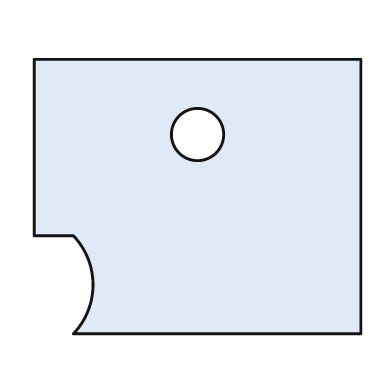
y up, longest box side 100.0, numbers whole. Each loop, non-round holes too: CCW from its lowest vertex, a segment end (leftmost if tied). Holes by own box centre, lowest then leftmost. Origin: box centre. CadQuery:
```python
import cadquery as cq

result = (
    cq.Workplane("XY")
    .moveTo(-38.0, -42.0)
    .lineTo(50.0, -42.0)
    .lineTo(50.0, 42.0)
    .lineTo(-50.0, 42.0)
    .lineTo(-50.0, -12.0)
    .lineTo(-38.0, -12.0)
    .threePointArc((-32.0, -27.0), (-38.0, -42.0))
    .close()
    .moveTo(0.0, 19.0)
    .circle(8.0)
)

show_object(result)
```